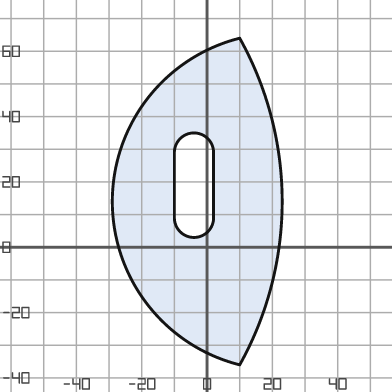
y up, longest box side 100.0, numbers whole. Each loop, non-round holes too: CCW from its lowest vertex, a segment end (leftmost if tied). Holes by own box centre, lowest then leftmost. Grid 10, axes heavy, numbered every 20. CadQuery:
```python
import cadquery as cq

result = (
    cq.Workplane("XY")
    .moveTo(10.0, -36.0)
    .threePointArc((23.0, 14.0), (10.0, 64.0))
    .threePointArc((-29.0, 14.0), (10.0, -36.0))
    .close()
    .moveTo(-10.0, 9.0)
    .threePointArc((-4.0, 3.0), (2.0, 9.0))
    .lineTo(2.0, 29.0)
    .threePointArc((-4.0, 35.0), (-10.0, 29.0))
    .close()
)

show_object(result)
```